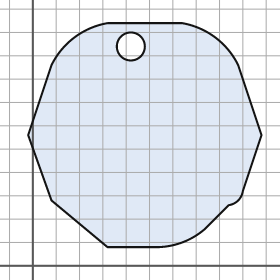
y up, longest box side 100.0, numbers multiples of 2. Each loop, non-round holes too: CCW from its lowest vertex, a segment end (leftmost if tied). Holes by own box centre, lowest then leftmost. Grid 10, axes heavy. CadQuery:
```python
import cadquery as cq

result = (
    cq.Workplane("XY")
    .moveTo(32.0, 8.0)
    .lineTo(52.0, 8.0)
    .threePointArc((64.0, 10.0), (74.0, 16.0))
    .lineTo(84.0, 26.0)
    .threePointArc((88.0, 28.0), (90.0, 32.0))
    .lineTo(98.0, 56.0)
    .lineTo(88.0, 86.0)
    .threePointArc((78.0, 98.0), (64.0, 104.0))
    .lineTo(32.0, 104.0)
    .threePointArc((18.0, 98.0), (8.0, 86.0))
    .lineTo(-2.0, 56.0)
    .lineTo(8.0, 28.0)
    .close()
    .moveTo(42.0, 94.0)
    .circle(6.0)
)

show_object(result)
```